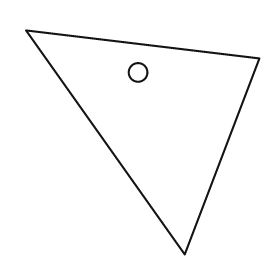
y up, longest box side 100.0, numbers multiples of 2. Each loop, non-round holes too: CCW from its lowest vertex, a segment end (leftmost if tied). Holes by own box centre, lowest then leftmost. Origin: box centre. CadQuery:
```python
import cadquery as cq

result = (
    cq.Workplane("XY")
    .moveTo(18.0, -48.0)
    .lineTo(50.0, 36.0)
    .lineTo(-50.0, 48.0)
    .close()
    .moveTo(-2.0, 30.0)
    .circle(4.0)
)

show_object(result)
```